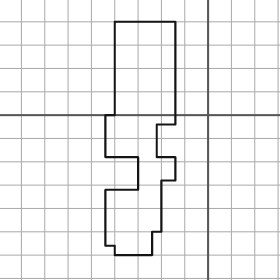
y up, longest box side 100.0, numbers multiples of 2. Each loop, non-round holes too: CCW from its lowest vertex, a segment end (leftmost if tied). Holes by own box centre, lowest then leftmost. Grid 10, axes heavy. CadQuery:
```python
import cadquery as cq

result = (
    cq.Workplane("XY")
    .moveTo(-40.0, -60.0)
    .lineTo(-24.0, -60.0)
    .lineTo(-24.0, -50.0)
    .lineTo(-20.0, -50.0)
    .lineTo(-20.0, -28.0)
    .lineTo(-14.0, -28.0)
    .lineTo(-14.0, -18.0)
    .lineTo(-22.0, -18.0)
    .lineTo(-22.0, -4.0)
    .lineTo(-14.0, -4.0)
    .lineTo(-14.0, 40.0)
    .lineTo(-40.0, 40.0)
    .lineTo(-40.0, 0.0)
    .lineTo(-44.0, 0.0)
    .lineTo(-44.0, -18.0)
    .lineTo(-30.0, -18.0)
    .lineTo(-30.0, -32.0)
    .lineTo(-44.0, -32.0)
    .lineTo(-44.0, -56.0)
    .lineTo(-40.0, -56.0)
    .close()
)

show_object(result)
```